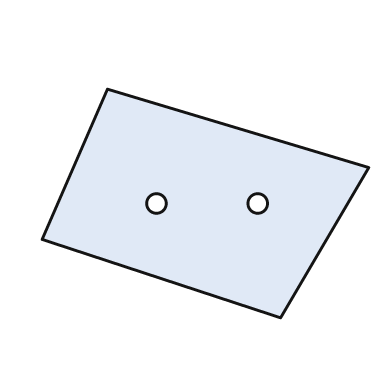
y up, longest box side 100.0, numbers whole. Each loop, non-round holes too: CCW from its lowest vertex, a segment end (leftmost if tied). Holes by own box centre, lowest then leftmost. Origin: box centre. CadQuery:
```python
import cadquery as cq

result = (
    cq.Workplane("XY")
    .moveTo(23.0, -35.0)
    .lineTo(50.0, 11.0)
    .lineTo(-30.0, 35.0)
    .lineTo(-50.0, -11.0)
    .close()
    .moveTo(-15.0, 0.0)
    .circle(3.0)
    .moveTo(16.0, 0.0)
    .circle(3.0)
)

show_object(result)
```